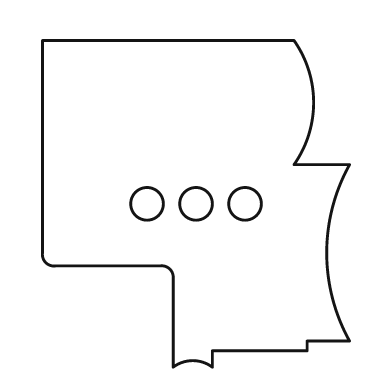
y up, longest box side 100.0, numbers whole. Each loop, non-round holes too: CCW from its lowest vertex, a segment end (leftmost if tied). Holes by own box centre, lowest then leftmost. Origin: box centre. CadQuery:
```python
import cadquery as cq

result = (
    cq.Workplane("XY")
    .moveTo(-7.0, -50.0)
    .threePointArc((-1.0, -48.0), (5.0, -50.0))
    .lineTo(5.0, -45.0)
    .lineTo(34.0, -45.0)
    .lineTo(34.0, -42.0)
    .lineTo(47.0, -42.0)
    .threePointArc((40.0, -15.0), (47.0, 12.0))
    .lineTo(30.0, 12.0)
    .threePointArc((36.0, 31.0), (30.0, 50.0))
    .lineTo(-47.0, 50.0)
    .lineTo(-47.0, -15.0)
    .threePointArc((-46.0, -18.0), (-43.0, -19.0))
    .lineTo(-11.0, -19.0)
    .threePointArc((-8.0, -20.0), (-7.0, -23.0))
    .close()
    .moveTo(-15.0, 0.0)
    .circle(5.0)
    .moveTo(0.0, 0.0)
    .circle(5.0)
    .moveTo(15.0, 0.0)
    .circle(5.0)
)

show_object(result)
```